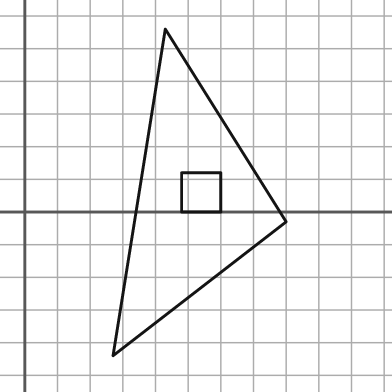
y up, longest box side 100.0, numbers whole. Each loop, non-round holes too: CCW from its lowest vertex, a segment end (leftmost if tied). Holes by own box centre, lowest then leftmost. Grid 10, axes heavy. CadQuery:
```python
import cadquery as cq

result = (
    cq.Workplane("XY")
    .moveTo(27.0, -44.0)
    .lineTo(80.0, -3.0)
    .lineTo(43.0, 56.0)
    .close()
    .moveTo(48.0, 0.0)
    .lineTo(60.0, 0.0)
    .lineTo(60.0, 12.0)
    .lineTo(48.0, 12.0)
    .close()
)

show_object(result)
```